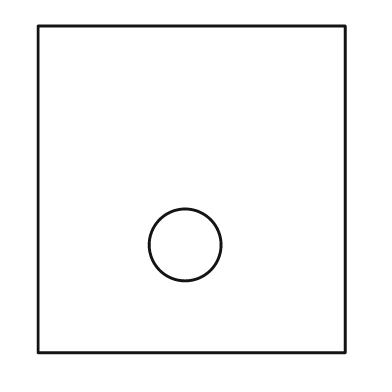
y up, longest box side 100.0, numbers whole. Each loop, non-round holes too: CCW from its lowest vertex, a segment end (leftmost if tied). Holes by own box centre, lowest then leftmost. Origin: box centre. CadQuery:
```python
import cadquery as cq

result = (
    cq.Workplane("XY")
    .moveTo(-47.0, -50.0)
    .lineTo(47.0, -50.0)
    .lineTo(47.0, 50.0)
    .lineTo(-47.0, 50.0)
    .close()
    .moveTo(-2.0, -17.0)
    .circle(11.0)
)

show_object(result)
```